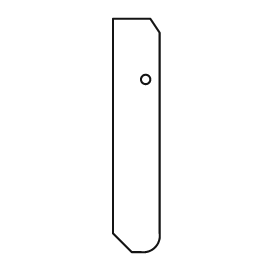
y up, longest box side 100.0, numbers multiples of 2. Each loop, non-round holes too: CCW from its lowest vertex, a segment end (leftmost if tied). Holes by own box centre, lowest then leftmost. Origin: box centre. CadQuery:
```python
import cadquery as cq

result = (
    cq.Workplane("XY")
    .moveTo(-2.0, -50.0)
    .lineTo(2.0, -50.0)
    .threePointArc((8.0, -48.0), (10.0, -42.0))
    .lineTo(10.0, 44.0)
    .lineTo(6.0, 50.0)
    .lineTo(-10.0, 50.0)
    .lineTo(-10.0, -42.0)
    .close()
    .moveTo(4.0, 24.0)
    .circle(2.0)
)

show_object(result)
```